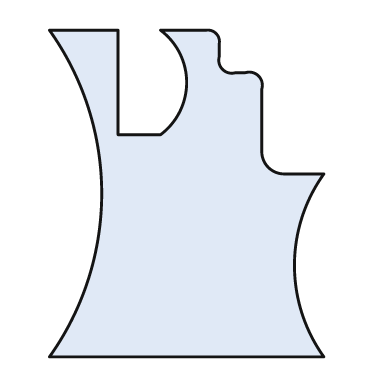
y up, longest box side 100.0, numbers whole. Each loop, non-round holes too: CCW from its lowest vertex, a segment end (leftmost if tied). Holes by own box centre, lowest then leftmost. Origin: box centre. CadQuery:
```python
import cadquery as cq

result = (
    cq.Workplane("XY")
    .moveTo(-42.0, -50.0)
    .lineTo(42.0, -50.0)
    .threePointArc((33.0, -22.0), (42.0, 6.0))
    .lineTo(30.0, 6.0)
    .threePointArc((25.0, 8.0), (23.0, 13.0))
    .lineTo(23.0, 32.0)
    .threePointArc((22.0, 36.0), (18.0, 37.0))
    .lineTo(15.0, 37.0)
    .threePointArc((11.0, 38.0), (10.0, 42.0))
    .lineTo(10.0, 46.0)
    .threePointArc((9.0, 49.0), (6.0, 50.0))
    .lineTo(-8.0, 50.0)
    .threePointArc((0.0, 34.0), (-8.0, 18.0))
    .lineTo(-21.0, 18.0)
    .lineTo(-21.0, 50.0)
    .lineTo(-42.0, 50.0)
    .threePointArc((-26.0, 0.0), (-42.0, -50.0))
    .close()
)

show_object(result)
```